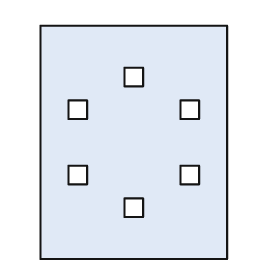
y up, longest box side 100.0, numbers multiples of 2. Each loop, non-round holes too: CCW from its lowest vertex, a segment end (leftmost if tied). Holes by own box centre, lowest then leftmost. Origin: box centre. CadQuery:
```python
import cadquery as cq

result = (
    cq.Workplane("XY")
    .moveTo(-40.0, -50.0)
    .lineTo(40.0, -50.0)
    .lineTo(40.0, 50.0)
    .lineTo(-40.0, 50.0)
    .close()
    .moveTo(-4.0, -32.0)
    .lineTo(4.0, -32.0)
    .lineTo(4.0, -24.0)
    .lineTo(-4.0, -24.0)
    .close()
    .moveTo(-28.0, -18.0)
    .lineTo(-20.0, -18.0)
    .lineTo(-20.0, -10.0)
    .lineTo(-28.0, -10.0)
    .close()
    .moveTo(20.0, -18.0)
    .lineTo(28.0, -18.0)
    .lineTo(28.0, -10.0)
    .lineTo(20.0, -10.0)
    .close()
    .moveTo(-28.0, 10.0)
    .lineTo(-20.0, 10.0)
    .lineTo(-20.0, 18.0)
    .lineTo(-28.0, 18.0)
    .close()
    .moveTo(20.0, 10.0)
    .lineTo(28.0, 10.0)
    .lineTo(28.0, 18.0)
    .lineTo(20.0, 18.0)
    .close()
    .moveTo(-4.0, 24.0)
    .lineTo(4.0, 24.0)
    .lineTo(4.0, 32.0)
    .lineTo(-4.0, 32.0)
    .close()
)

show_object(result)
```